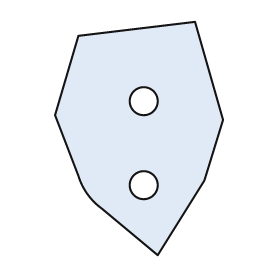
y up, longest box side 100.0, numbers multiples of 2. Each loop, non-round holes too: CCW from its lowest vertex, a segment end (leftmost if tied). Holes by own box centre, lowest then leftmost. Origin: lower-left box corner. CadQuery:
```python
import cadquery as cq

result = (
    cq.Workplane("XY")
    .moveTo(44.0, 0.0)
    .lineTo(64.0, 32.0)
    .lineTo(72.0, 58.0)
    .lineTo(60.0, 100.0)
    .lineTo(10.0, 94.0)
    .lineTo(0.0, 60.0)
    .lineTo(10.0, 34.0)
    .threePointArc((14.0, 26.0), (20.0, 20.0))
    .close()
    .moveTo(38.0, 30.0)
    .circle(6.0)
    .moveTo(38.0, 66.0)
    .circle(6.0)
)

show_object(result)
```